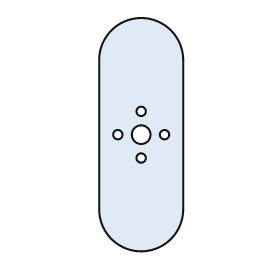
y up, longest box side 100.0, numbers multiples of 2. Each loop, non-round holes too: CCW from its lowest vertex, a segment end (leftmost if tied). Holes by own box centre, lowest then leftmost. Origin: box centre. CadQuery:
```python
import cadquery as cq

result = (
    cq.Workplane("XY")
    .moveTo(-18.0, -32.0)
    .threePointArc((0.0, -50.0), (18.0, -32.0))
    .lineTo(18.0, 32.0)
    .threePointArc((0.0, 50.0), (-18.0, 32.0))
    .close()
    .moveTo(0.0, -10.0)
    .circle(2.0)
    .moveTo(-10.0, 0.0)
    .circle(2.0)
    .moveTo(0.0, 0.0)
    .circle(4.0)
    .moveTo(10.0, 0.0)
    .circle(2.0)
    .moveTo(0.0, 10.0)
    .circle(2.0)
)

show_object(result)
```